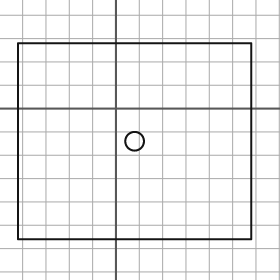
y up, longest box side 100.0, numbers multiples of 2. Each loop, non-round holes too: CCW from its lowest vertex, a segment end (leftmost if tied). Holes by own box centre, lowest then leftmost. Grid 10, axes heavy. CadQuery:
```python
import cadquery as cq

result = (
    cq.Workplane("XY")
    .moveTo(-42.0, -56.0)
    .lineTo(58.0, -56.0)
    .lineTo(58.0, 28.0)
    .lineTo(-42.0, 28.0)
    .close()
    .moveTo(8.0, -14.0)
    .circle(4.0)
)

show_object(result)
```